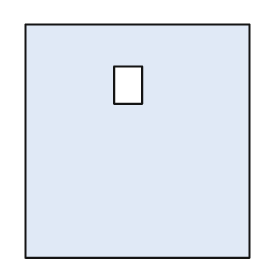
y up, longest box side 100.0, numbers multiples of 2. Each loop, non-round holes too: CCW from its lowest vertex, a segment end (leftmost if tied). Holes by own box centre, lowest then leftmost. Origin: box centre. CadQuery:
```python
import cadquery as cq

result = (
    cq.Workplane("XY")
    .moveTo(-48.0, -50.0)
    .lineTo(48.0, -50.0)
    .lineTo(48.0, 50.0)
    .lineTo(-48.0, 50.0)
    .close()
    .moveTo(-10.0, 16.0)
    .lineTo(2.0, 16.0)
    .lineTo(2.0, 32.0)
    .lineTo(-10.0, 32.0)
    .close()
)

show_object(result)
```